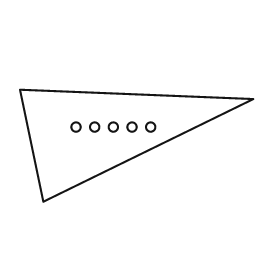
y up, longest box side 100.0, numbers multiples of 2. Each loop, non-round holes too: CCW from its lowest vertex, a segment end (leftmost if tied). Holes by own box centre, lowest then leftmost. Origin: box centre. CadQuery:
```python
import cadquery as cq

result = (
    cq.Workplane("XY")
    .moveTo(-40.0, -24.0)
    .lineTo(50.0, 20.0)
    .lineTo(-50.0, 24.0)
    .close()
    .moveTo(-26.0, 8.0)
    .circle(2.0)
    .moveTo(-18.0, 8.0)
    .circle(2.0)
    .moveTo(-10.0, 8.0)
    .circle(2.0)
    .moveTo(-2.0, 8.0)
    .circle(2.0)
    .moveTo(6.0, 8.0)
    .circle(2.0)
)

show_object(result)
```